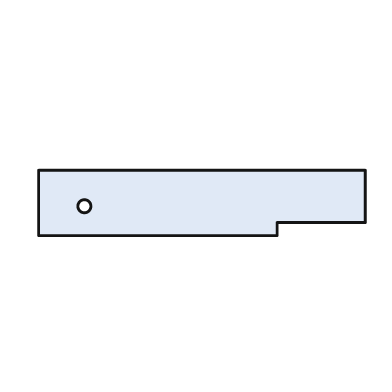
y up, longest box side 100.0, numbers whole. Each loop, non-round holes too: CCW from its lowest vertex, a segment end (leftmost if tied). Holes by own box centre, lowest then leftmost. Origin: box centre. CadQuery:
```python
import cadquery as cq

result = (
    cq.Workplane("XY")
    .moveTo(-50.0, -10.0)
    .lineTo(23.0, -10.0)
    .lineTo(23.0, -6.0)
    .lineTo(50.0, -6.0)
    .lineTo(50.0, 10.0)
    .lineTo(-50.0, 10.0)
    .close()
    .moveTo(-36.0, -1.0)
    .circle(2.0)
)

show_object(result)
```